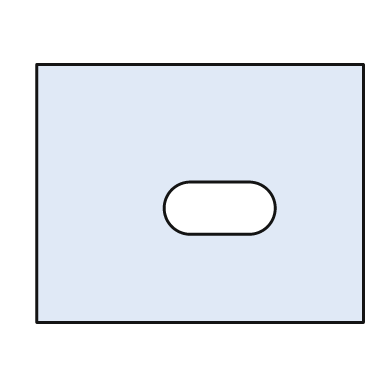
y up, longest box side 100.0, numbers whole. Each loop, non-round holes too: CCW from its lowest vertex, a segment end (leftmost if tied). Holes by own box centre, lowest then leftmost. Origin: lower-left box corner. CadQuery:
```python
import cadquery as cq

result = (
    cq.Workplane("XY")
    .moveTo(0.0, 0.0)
    .lineTo(100.0, 0.0)
    .lineTo(100.0, 79.0)
    .lineTo(0.0, 79.0)
    .close()
    .moveTo(47.0, 27.0)
    .lineTo(65.0, 27.0)
    .threePointArc((73.0, 35.0), (65.0, 43.0))
    .lineTo(47.0, 43.0)
    .threePointArc((39.0, 35.0), (47.0, 27.0))
    .close()
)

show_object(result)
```